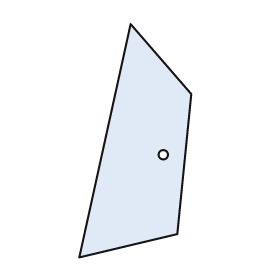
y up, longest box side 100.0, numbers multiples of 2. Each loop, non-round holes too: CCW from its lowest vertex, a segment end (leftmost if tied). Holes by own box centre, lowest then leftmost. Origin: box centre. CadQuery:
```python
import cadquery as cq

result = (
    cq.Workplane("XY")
    .moveTo(-24.0, -50.0)
    .lineTo(18.0, -40.0)
    .lineTo(24.0, 20.0)
    .lineTo(-2.0, 50.0)
    .close()
    .moveTo(12.0, -6.0)
    .circle(2.0)
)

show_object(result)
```